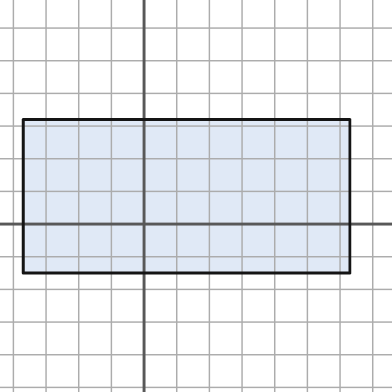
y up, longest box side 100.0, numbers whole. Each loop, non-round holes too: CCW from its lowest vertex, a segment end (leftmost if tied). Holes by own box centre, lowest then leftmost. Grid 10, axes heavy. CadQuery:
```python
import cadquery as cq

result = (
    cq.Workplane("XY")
    .moveTo(-37.0, -15.0)
    .lineTo(63.0, -15.0)
    .lineTo(63.0, 32.0)
    .lineTo(-37.0, 32.0)
    .close()
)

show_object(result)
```